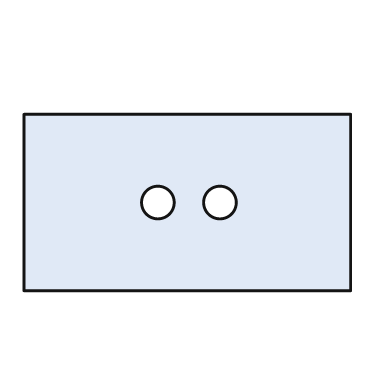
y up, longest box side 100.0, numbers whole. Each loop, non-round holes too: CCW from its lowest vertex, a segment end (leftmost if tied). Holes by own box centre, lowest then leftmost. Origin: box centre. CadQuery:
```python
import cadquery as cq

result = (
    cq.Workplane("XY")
    .moveTo(-50.0, -27.0)
    .lineTo(50.0, -27.0)
    .lineTo(50.0, 27.0)
    .lineTo(-50.0, 27.0)
    .close()
    .moveTo(-9.0, 0.0)
    .circle(5.0)
    .moveTo(10.0, 0.0)
    .circle(5.0)
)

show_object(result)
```